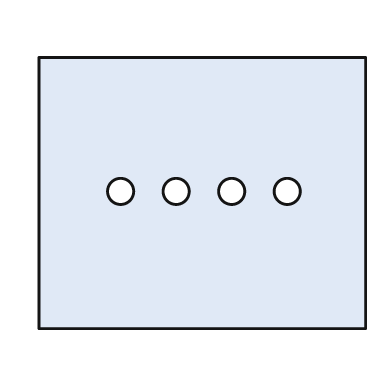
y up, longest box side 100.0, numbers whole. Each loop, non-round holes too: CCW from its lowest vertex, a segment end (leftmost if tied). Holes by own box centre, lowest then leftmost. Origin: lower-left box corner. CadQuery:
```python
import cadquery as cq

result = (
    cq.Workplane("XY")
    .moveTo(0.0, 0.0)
    .lineTo(100.0, 0.0)
    .lineTo(100.0, 83.0)
    .lineTo(0.0, 83.0)
    .close()
    .moveTo(25.0, 42.0)
    .circle(4.0)
    .moveTo(42.0, 42.0)
    .circle(4.0)
    .moveTo(59.0, 42.0)
    .circle(4.0)
    .moveTo(76.0, 42.0)
    .circle(4.0)
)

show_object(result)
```